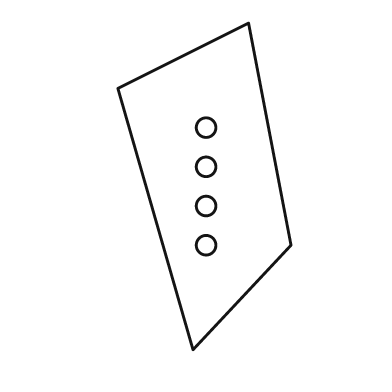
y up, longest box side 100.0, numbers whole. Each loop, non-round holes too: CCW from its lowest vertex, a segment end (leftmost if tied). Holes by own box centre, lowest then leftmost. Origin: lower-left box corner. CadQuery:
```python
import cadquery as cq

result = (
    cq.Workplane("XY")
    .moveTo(23.0, 0.0)
    .lineTo(53.0, 32.0)
    .lineTo(40.0, 100.0)
    .lineTo(0.0, 80.0)
    .close()
    .moveTo(27.0, 32.0)
    .circle(3.0)
    .moveTo(27.0, 44.0)
    .circle(3.0)
    .moveTo(27.0, 56.0)
    .circle(3.0)
    .moveTo(27.0, 68.0)
    .circle(3.0)
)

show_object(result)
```